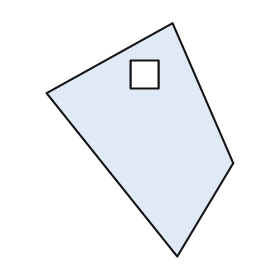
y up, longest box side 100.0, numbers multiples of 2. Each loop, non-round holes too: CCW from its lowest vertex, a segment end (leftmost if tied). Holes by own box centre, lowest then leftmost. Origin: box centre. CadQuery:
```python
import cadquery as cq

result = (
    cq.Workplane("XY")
    .moveTo(16.0, -50.0)
    .lineTo(40.0, -10.0)
    .lineTo(14.0, 50.0)
    .lineTo(-40.0, 20.0)
    .close()
    .moveTo(-4.0, 22.0)
    .lineTo(8.0, 22.0)
    .lineTo(8.0, 34.0)
    .lineTo(-4.0, 34.0)
    .close()
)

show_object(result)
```